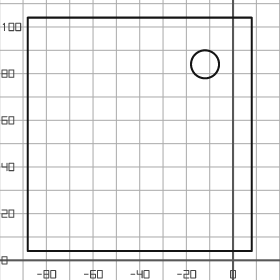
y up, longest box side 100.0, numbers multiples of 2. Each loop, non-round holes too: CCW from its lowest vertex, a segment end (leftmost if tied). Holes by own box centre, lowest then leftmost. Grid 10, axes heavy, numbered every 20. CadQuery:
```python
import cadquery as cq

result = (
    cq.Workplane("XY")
    .moveTo(-88.0, 4.0)
    .lineTo(8.0, 4.0)
    .lineTo(8.0, 104.0)
    .lineTo(-88.0, 104.0)
    .close()
    .moveTo(-12.0, 84.0)
    .circle(6.0)
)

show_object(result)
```